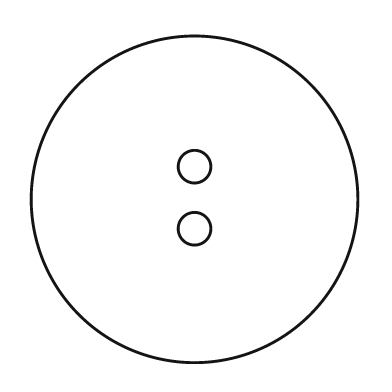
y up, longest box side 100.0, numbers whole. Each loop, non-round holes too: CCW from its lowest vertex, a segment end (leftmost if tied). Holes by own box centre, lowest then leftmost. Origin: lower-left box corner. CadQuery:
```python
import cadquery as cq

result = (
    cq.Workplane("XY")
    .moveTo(50.0, 50.0)
    .circle(50.0)
    .moveTo(50.0, 41.0)
    .circle(5.0)
    .moveTo(50.0, 60.0)
    .circle(5.0)
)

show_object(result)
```